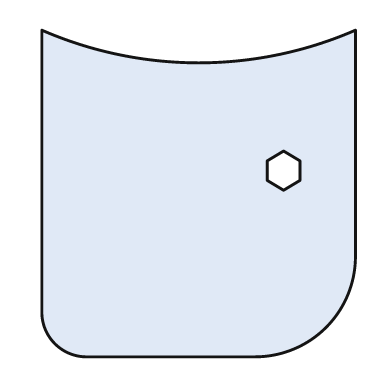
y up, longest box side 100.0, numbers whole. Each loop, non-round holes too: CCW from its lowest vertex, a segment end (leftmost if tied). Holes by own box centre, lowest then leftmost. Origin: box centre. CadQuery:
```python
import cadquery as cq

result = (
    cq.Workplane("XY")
    .moveTo(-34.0, -50.0)
    .lineTo(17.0, -50.0)
    .threePointArc((39.0, -41.0), (48.0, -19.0))
    .lineTo(48.0, 50.0)
    .threePointArc((0.0, 40.0), (-48.0, 50.0))
    .lineTo(-48.0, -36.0)
    .threePointArc((-44.0, -46.0), (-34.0, -50.0))
    .close()
    .moveTo(26.0, 1.0)
    .lineTo(31.0, 4.0)
    .lineTo(31.0, 10.0)
    .lineTo(26.0, 13.0)
    .lineTo(21.0, 10.0)
    .lineTo(21.0, 4.0)
    .close()
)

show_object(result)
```